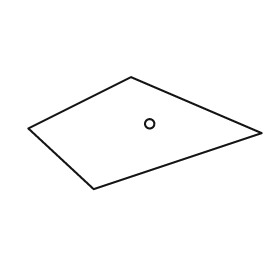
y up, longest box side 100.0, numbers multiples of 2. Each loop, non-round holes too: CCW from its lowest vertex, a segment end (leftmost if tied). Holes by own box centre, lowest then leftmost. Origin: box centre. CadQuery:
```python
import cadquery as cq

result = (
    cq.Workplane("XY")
    .moveTo(-22.0, -24.0)
    .lineTo(50.0, 0.0)
    .lineTo(-6.0, 24.0)
    .lineTo(-50.0, 2.0)
    .close()
    .moveTo(2.0, 4.0)
    .circle(2.0)
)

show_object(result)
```